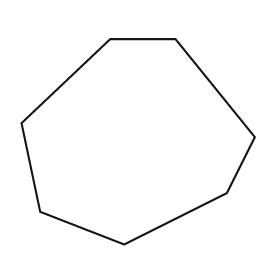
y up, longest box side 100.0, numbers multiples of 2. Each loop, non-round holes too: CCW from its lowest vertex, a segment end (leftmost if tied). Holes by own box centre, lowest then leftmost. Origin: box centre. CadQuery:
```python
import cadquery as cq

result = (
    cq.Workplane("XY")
    .moveTo(-6.0, -44.0)
    .lineTo(38.0, -22.0)
    .lineTo(50.0, 2.0)
    .lineTo(16.0, 44.0)
    .lineTo(-12.0, 44.0)
    .lineTo(-50.0, 8.0)
    .lineTo(-42.0, -30.0)
    .close()
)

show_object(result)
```